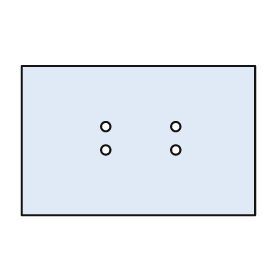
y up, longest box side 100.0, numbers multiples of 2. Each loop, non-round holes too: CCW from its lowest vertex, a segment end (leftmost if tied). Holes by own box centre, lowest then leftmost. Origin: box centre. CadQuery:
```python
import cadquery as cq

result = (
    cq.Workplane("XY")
    .moveTo(-50.0, -32.0)
    .lineTo(50.0, -32.0)
    .lineTo(50.0, 32.0)
    .lineTo(-50.0, 32.0)
    .close()
    .moveTo(-14.0, -4.0)
    .circle(2.0)
    .moveTo(16.0, -4.0)
    .circle(2.0)
    .moveTo(-14.0, 6.0)
    .circle(2.0)
    .moveTo(16.0, 6.0)
    .circle(2.0)
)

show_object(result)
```